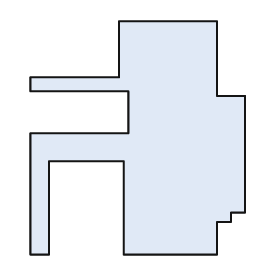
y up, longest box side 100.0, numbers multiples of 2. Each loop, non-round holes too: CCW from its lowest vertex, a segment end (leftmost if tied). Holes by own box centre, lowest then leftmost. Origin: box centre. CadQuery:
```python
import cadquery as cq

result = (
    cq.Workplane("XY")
    .moveTo(-46.0, -50.0)
    .lineTo(-38.0, -50.0)
    .lineTo(-38.0, -10.0)
    .lineTo(-6.0, -10.0)
    .lineTo(-6.0, -50.0)
    .lineTo(34.0, -50.0)
    .lineTo(34.0, -36.0)
    .lineTo(40.0, -36.0)
    .lineTo(40.0, -32.0)
    .lineTo(46.0, -32.0)
    .lineTo(46.0, 18.0)
    .lineTo(34.0, 18.0)
    .lineTo(34.0, 50.0)
    .lineTo(-8.0, 50.0)
    .lineTo(-8.0, 26.0)
    .lineTo(-46.0, 26.0)
    .lineTo(-46.0, 20.0)
    .lineTo(-4.0, 20.0)
    .lineTo(-4.0, 2.0)
    .lineTo(-46.0, 2.0)
    .close()
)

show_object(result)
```